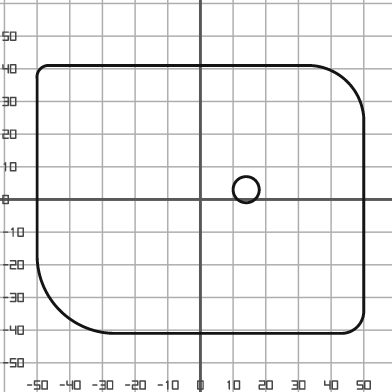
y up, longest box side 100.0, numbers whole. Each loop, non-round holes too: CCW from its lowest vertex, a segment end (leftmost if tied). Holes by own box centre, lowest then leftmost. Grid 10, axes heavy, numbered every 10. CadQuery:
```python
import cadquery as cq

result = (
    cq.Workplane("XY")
    .moveTo(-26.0, -41.0)
    .lineTo(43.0, -41.0)
    .threePointArc((48.0, -39.0), (50.0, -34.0))
    .lineTo(50.0, 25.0)
    .threePointArc((45.0, 36.0), (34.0, 41.0))
    .lineTo(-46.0, 41.0)
    .threePointArc((-49.0, 40.0), (-50.0, 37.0))
    .lineTo(-50.0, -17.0)
    .threePointArc((-43.0, -34.0), (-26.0, -41.0))
    .close()
    .moveTo(14.0, 3.0)
    .circle(4.0)
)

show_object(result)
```